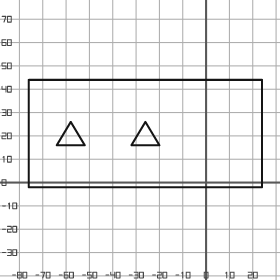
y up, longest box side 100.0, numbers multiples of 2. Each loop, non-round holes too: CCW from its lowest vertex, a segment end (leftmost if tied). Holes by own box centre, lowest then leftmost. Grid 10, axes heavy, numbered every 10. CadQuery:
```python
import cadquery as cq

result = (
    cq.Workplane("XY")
    .moveTo(-76.0, -2.0)
    .lineTo(24.0, -2.0)
    .lineTo(24.0, 44.0)
    .lineTo(-76.0, 44.0)
    .close()
    .moveTo(-64.0, 16.0)
    .lineTo(-52.0, 16.0)
    .lineTo(-58.0, 26.0)
    .close()
    .moveTo(-32.0, 16.0)
    .lineTo(-20.0, 16.0)
    .lineTo(-26.0, 26.0)
    .close()
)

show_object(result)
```